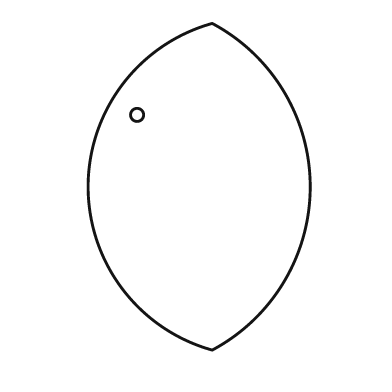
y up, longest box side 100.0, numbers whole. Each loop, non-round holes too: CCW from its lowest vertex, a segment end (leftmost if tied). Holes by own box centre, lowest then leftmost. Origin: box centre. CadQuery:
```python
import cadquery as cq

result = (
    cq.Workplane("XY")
    .moveTo(4.0, -50.0)
    .threePointArc((34.0, 0.0), (4.0, 50.0))
    .threePointArc((-34.0, 0.0), (4.0, -50.0))
    .close()
    .moveTo(-19.0, 22.0)
    .circle(2.0)
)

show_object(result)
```